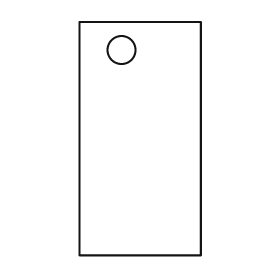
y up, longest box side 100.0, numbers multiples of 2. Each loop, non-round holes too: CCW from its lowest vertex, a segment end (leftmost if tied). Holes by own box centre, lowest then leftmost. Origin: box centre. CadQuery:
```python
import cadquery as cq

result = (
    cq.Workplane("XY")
    .moveTo(-26.0, -50.0)
    .lineTo(26.0, -50.0)
    .lineTo(26.0, 50.0)
    .lineTo(-26.0, 50.0)
    .close()
    .moveTo(-8.0, 38.0)
    .circle(6.0)
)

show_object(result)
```